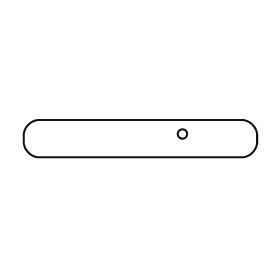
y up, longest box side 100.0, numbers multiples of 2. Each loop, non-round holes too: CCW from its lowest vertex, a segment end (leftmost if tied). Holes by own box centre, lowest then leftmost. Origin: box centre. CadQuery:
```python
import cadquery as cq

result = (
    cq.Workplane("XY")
    .moveTo(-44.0, -8.0)
    .lineTo(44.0, -8.0)
    .threePointArc((48.0, -6.0), (50.0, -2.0))
    .lineTo(50.0, 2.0)
    .threePointArc((48.0, 6.0), (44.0, 8.0))
    .lineTo(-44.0, 8.0)
    .threePointArc((-48.0, 6.0), (-50.0, 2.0))
    .lineTo(-50.0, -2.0)
    .threePointArc((-48.0, -6.0), (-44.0, -8.0))
    .close()
    .moveTo(18.0, 2.0)
    .circle(2.0)
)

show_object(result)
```